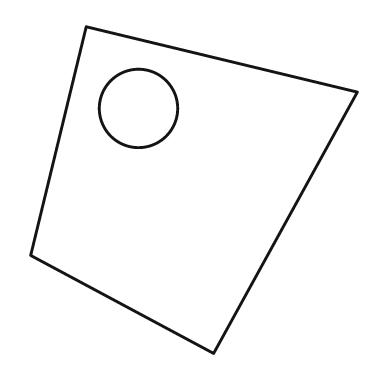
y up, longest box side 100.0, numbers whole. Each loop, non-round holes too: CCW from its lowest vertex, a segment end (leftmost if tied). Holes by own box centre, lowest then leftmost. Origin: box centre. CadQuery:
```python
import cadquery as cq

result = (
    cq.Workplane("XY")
    .moveTo(6.0, -50.0)
    .lineTo(50.0, 30.0)
    .lineTo(-33.0, 50.0)
    .lineTo(-50.0, -20.0)
    .close()
    .moveTo(-17.0, 25.0)
    .circle(12.0)
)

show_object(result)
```